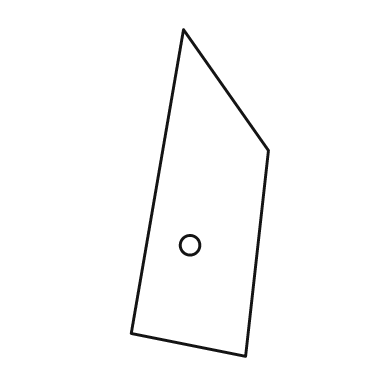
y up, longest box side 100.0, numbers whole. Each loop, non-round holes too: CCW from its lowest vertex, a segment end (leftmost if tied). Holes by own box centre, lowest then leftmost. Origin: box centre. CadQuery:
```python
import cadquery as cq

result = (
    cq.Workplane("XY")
    .moveTo(14.0, -50.0)
    .lineTo(21.0, 13.0)
    .lineTo(-5.0, 50.0)
    .lineTo(-21.0, -43.0)
    .close()
    .moveTo(-3.0, -16.0)
    .circle(3.0)
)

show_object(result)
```